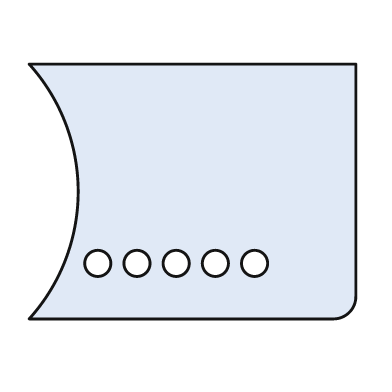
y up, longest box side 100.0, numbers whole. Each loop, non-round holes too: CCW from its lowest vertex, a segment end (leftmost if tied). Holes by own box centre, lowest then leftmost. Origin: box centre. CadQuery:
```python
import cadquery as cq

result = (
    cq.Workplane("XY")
    .moveTo(-50.0, -39.0)
    .lineTo(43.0, -39.0)
    .threePointArc((48.0, -37.0), (50.0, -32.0))
    .lineTo(50.0, 39.0)
    .lineTo(-50.0, 39.0)
    .threePointArc((-35.0, 0.0), (-50.0, -39.0))
    .close()
    .moveTo(-29.0, -22.0)
    .circle(4.0)
    .moveTo(-17.0, -22.0)
    .circle(4.0)
    .moveTo(-5.0, -22.0)
    .circle(4.0)
    .moveTo(7.0, -22.0)
    .circle(4.0)
    .moveTo(19.0, -22.0)
    .circle(4.0)
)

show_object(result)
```